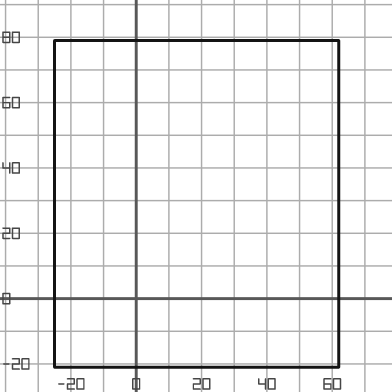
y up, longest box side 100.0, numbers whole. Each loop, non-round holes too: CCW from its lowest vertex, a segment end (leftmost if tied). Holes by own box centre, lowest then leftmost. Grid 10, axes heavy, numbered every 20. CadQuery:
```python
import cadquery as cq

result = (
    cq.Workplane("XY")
    .moveTo(-25.0, -21.0)
    .lineTo(62.0, -21.0)
    .lineTo(62.0, 79.0)
    .lineTo(-25.0, 79.0)
    .close()
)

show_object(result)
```